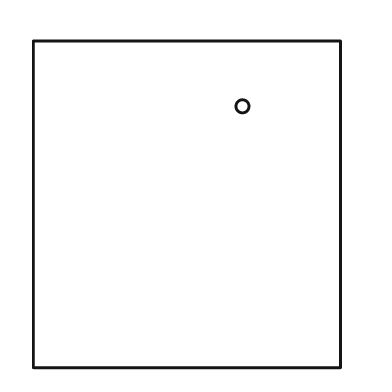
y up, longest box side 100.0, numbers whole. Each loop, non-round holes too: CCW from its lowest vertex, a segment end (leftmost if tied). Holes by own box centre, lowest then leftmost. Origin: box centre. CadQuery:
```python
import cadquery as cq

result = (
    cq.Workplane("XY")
    .moveTo(-47.0, -50.0)
    .lineTo(47.0, -50.0)
    .lineTo(47.0, 50.0)
    .lineTo(-47.0, 50.0)
    .close()
    .moveTo(17.0, 30.0)
    .circle(2.0)
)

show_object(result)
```